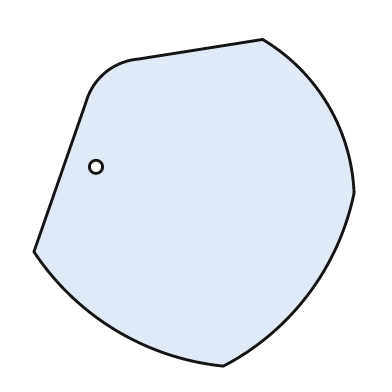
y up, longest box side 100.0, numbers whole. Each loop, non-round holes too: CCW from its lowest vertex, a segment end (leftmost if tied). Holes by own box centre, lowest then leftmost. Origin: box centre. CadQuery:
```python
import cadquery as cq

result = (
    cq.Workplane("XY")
    .moveTo(9.0, -50.0)
    .threePointArc((35.0, -28.0), (49.0, 3.0))
    .threePointArc((41.0, 30.0), (21.0, 50.0))
    .lineTo(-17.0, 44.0)
    .threePointArc((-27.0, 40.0), (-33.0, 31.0))
    .lineTo(-49.0, -15.0)
    .threePointArc((-24.0, -39.0), (9.0, -50.0))
    .close()
    .moveTo(-30.0, 11.0)
    .circle(2.0)
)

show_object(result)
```